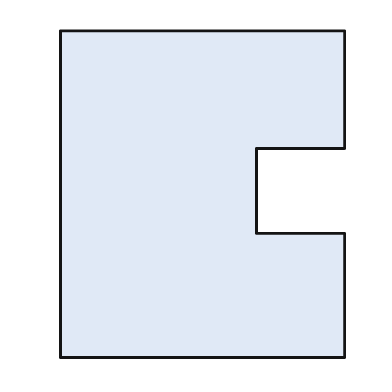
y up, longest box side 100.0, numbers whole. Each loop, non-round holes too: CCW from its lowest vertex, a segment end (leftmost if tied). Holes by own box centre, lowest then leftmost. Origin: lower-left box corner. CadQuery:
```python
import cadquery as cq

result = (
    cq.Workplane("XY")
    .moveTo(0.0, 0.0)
    .lineTo(87.0, 0.0)
    .lineTo(87.0, 38.0)
    .lineTo(60.0, 38.0)
    .lineTo(60.0, 64.0)
    .lineTo(87.0, 64.0)
    .lineTo(87.0, 100.0)
    .lineTo(0.0, 100.0)
    .close()
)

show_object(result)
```